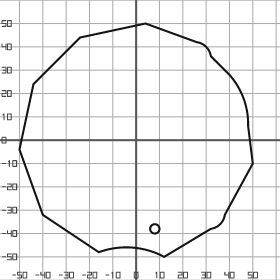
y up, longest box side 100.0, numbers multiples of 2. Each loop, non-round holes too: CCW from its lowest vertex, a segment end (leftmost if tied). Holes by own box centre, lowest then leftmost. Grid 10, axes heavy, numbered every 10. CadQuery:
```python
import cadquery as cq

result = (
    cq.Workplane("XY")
    .moveTo(12.0, -50.0)
    .lineTo(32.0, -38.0)
    .threePointArc((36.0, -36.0), (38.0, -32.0))
    .lineTo(50.0, -10.0)
    .lineTo(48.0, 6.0)
    .threePointArc((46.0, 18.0), (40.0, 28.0))
    .lineTo(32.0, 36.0)
    .threePointArc((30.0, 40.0), (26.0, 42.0))
    .lineTo(4.0, 50.0)
    .lineTo(-24.0, 44.0)
    .lineTo(-44.0, 24.0)
    .lineTo(-50.0, -4.0)
    .lineTo(-40.0, -32.0)
    .lineTo(-16.0, -48.0)
    .threePointArc((-2.0, -46.0), (12.0, -50.0))
    .close()
    .moveTo(8.0, -38.0)
    .circle(2.0)
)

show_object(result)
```